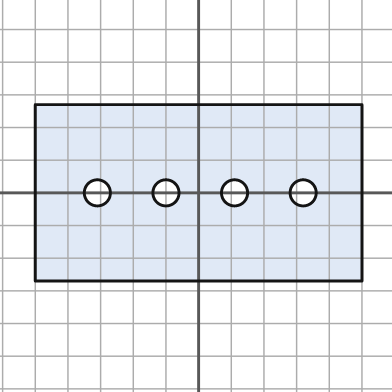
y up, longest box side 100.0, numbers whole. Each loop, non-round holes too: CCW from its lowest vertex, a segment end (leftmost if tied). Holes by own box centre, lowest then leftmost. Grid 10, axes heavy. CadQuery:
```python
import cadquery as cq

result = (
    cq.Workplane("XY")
    .moveTo(-50.0, -27.0)
    .lineTo(50.0, -27.0)
    .lineTo(50.0, 27.0)
    .lineTo(-50.0, 27.0)
    .close()
    .moveTo(-31.0, 0.0)
    .circle(4.0)
    .moveTo(-10.0, 0.0)
    .circle(4.0)
    .moveTo(11.0, 0.0)
    .circle(4.0)
    .moveTo(32.0, 0.0)
    .circle(4.0)
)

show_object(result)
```